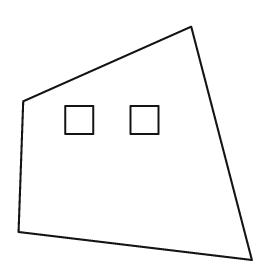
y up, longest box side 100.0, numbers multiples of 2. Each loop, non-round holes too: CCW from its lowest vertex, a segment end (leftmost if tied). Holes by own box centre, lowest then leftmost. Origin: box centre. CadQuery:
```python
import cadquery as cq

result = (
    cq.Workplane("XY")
    .moveTo(50.0, -50.0)
    .lineTo(24.0, 50.0)
    .lineTo(-48.0, 18.0)
    .lineTo(-50.0, -38.0)
    .close()
    .moveTo(-30.0, 4.0)
    .lineTo(-18.0, 4.0)
    .lineTo(-18.0, 16.0)
    .lineTo(-30.0, 16.0)
    .close()
    .moveTo(-2.0, 4.0)
    .lineTo(10.0, 4.0)
    .lineTo(10.0, 16.0)
    .lineTo(-2.0, 16.0)
    .close()
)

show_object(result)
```